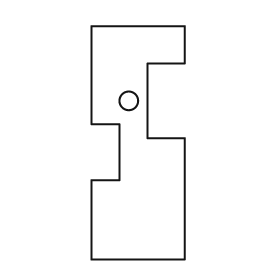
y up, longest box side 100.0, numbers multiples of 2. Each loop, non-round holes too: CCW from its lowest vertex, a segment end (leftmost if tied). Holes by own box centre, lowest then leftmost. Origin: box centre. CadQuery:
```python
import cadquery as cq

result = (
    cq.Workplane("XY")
    .moveTo(-20.0, -50.0)
    .lineTo(20.0, -50.0)
    .lineTo(20.0, 2.0)
    .lineTo(4.0, 2.0)
    .lineTo(4.0, 34.0)
    .lineTo(20.0, 34.0)
    .lineTo(20.0, 50.0)
    .lineTo(-20.0, 50.0)
    .lineTo(-20.0, 8.0)
    .lineTo(-8.0, 8.0)
    .lineTo(-8.0, -16.0)
    .lineTo(-20.0, -16.0)
    .close()
    .moveTo(-4.0, 18.0)
    .circle(4.0)
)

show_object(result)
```